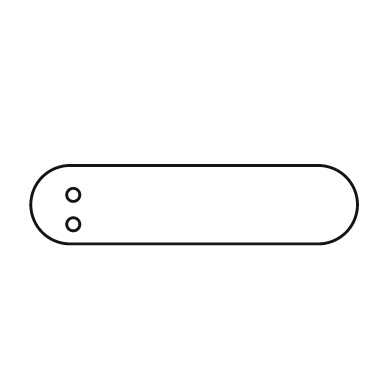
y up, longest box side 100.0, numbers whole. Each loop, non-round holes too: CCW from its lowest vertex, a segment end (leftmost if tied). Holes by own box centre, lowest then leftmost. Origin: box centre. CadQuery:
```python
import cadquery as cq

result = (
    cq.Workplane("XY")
    .moveTo(-38.0, -12.0)
    .lineTo(38.0, -12.0)
    .threePointArc((50.0, 0.0), (38.0, 12.0))
    .lineTo(-38.0, 12.0)
    .threePointArc((-50.0, 0.0), (-38.0, -12.0))
    .close()
    .moveTo(-37.0, -6.0)
    .circle(2.0)
    .moveTo(-37.0, 3.0)
    .circle(2.0)
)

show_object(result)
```